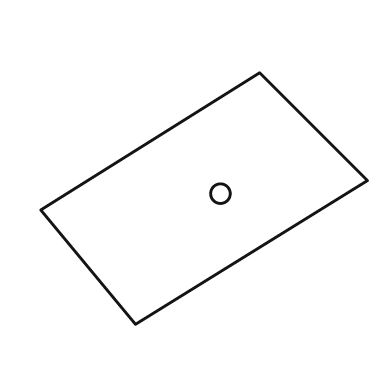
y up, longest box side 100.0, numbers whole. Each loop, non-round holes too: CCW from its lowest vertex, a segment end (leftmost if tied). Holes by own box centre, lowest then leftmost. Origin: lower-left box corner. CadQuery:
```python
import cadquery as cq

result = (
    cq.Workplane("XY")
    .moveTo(29.0, 0.0)
    .lineTo(100.0, 44.0)
    .lineTo(67.0, 77.0)
    .lineTo(0.0, 35.0)
    .close()
    .moveTo(55.0, 40.0)
    .circle(3.0)
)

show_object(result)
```